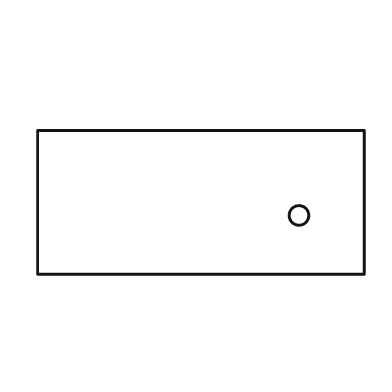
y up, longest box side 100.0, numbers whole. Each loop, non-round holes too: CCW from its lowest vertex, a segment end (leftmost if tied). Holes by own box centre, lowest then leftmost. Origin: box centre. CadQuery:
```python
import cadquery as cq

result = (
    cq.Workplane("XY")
    .moveTo(-50.0, -22.0)
    .lineTo(50.0, -22.0)
    .lineTo(50.0, 22.0)
    .lineTo(-50.0, 22.0)
    .close()
    .moveTo(30.0, -4.0)
    .circle(3.0)
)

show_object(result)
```